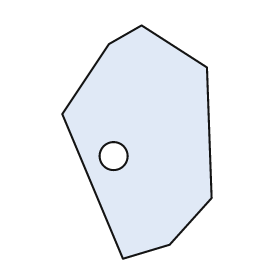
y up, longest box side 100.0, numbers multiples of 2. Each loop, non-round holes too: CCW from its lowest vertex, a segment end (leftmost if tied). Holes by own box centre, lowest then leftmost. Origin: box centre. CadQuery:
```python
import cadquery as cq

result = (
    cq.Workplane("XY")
    .moveTo(-6.0, -50.0)
    .lineTo(14.0, -44.0)
    .lineTo(32.0, -24.0)
    .lineTo(30.0, 32.0)
    .lineTo(2.0, 50.0)
    .lineTo(-12.0, 42.0)
    .lineTo(-32.0, 12.0)
    .close()
    .moveTo(-10.0, -6.0)
    .circle(6.0)
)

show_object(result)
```